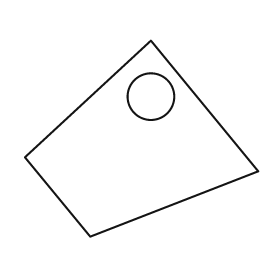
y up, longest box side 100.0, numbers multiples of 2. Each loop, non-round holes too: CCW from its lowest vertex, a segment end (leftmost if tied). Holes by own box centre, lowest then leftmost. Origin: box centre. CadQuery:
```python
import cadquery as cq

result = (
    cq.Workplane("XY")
    .moveTo(-22.0, -42.0)
    .lineTo(50.0, -14.0)
    .lineTo(4.0, 42.0)
    .lineTo(-50.0, -8.0)
    .close()
    .moveTo(4.0, 18.0)
    .circle(10.0)
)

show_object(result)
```